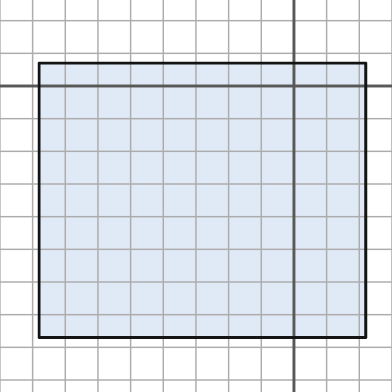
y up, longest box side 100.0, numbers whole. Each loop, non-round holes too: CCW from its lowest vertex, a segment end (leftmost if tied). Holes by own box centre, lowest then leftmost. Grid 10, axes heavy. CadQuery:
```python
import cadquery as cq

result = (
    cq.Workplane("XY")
    .moveTo(-78.0, -77.0)
    .lineTo(22.0, -77.0)
    .lineTo(22.0, 7.0)
    .lineTo(-78.0, 7.0)
    .close()
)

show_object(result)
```